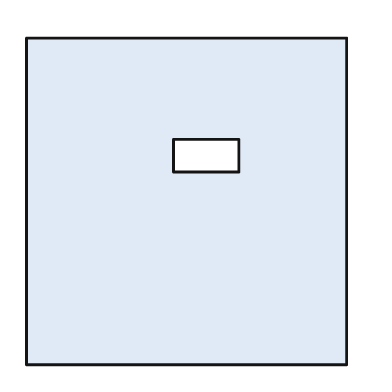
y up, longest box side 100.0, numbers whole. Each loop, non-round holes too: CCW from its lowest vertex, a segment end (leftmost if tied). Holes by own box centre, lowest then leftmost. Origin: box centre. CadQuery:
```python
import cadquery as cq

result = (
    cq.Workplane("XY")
    .moveTo(-49.0, -50.0)
    .lineTo(49.0, -50.0)
    .lineTo(49.0, 50.0)
    .lineTo(-49.0, 50.0)
    .close()
    .moveTo(-4.0, 9.0)
    .lineTo(16.0, 9.0)
    .lineTo(16.0, 19.0)
    .lineTo(-4.0, 19.0)
    .close()
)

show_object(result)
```